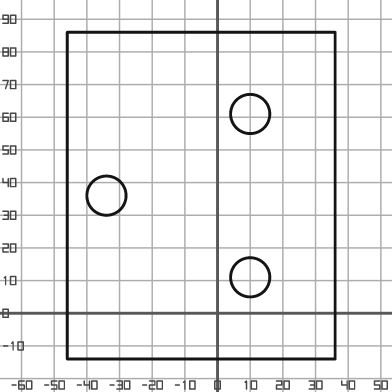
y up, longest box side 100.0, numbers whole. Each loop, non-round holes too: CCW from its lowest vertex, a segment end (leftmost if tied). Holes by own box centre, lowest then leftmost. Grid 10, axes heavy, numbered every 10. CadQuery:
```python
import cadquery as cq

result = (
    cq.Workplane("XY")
    .moveTo(-46.0, -14.0)
    .lineTo(36.0, -14.0)
    .lineTo(36.0, 86.0)
    .lineTo(-46.0, 86.0)
    .close()
    .moveTo(10.0, 11.0)
    .circle(6.0)
    .moveTo(-34.0, 36.0)
    .circle(6.0)
    .moveTo(10.0, 61.0)
    .circle(6.0)
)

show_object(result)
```